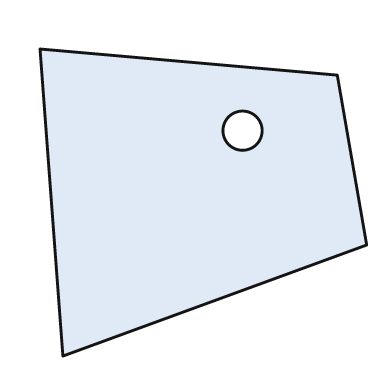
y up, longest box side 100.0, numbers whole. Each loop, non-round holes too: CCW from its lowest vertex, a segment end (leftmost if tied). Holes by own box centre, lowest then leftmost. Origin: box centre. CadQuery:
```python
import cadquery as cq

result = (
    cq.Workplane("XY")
    .moveTo(-43.0, -47.0)
    .lineTo(50.0, -13.0)
    .lineTo(41.0, 39.0)
    .lineTo(-50.0, 47.0)
    .close()
    .moveTo(12.0, 22.0)
    .circle(6.0)
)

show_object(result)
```